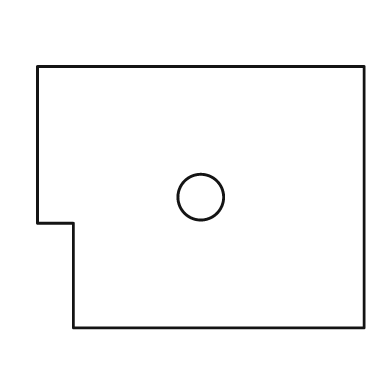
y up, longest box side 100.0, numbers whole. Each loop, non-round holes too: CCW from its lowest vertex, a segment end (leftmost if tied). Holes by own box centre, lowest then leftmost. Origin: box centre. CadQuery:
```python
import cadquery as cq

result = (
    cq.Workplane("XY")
    .moveTo(-39.0, -40.0)
    .lineTo(50.0, -40.0)
    .lineTo(50.0, 40.0)
    .lineTo(-50.0, 40.0)
    .lineTo(-50.0, -8.0)
    .lineTo(-39.0, -8.0)
    .close()
    .moveTo(0.0, 0.0)
    .circle(7.0)
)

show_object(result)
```